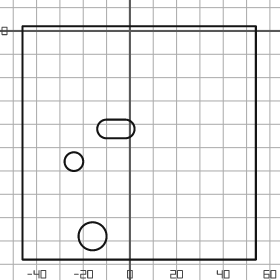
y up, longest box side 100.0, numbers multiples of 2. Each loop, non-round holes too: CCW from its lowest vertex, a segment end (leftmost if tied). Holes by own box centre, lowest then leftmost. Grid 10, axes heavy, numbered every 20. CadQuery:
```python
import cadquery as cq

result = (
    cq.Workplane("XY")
    .moveTo(-46.0, -98.0)
    .lineTo(54.0, -98.0)
    .lineTo(54.0, 2.0)
    .lineTo(-46.0, 2.0)
    .close()
    .moveTo(-16.0, -88.0)
    .circle(6.0)
    .moveTo(-24.0, -56.0)
    .circle(4.0)
    .moveTo(-10.0, -46.0)
    .lineTo(-2.0, -46.0)
    .threePointArc((2.0, -42.0), (-2.0, -38.0))
    .lineTo(-10.0, -38.0)
    .threePointArc((-14.0, -42.0), (-10.0, -46.0))
    .close()
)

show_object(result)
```